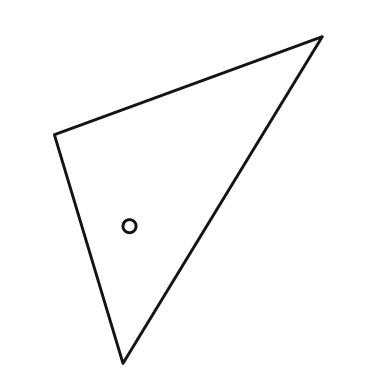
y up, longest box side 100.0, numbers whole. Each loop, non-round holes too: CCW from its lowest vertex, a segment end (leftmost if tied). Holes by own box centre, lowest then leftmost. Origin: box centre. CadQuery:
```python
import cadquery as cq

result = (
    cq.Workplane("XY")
    .moveTo(-20.0, -50.0)
    .lineTo(41.0, 50.0)
    .lineTo(-41.0, 20.0)
    .close()
    .moveTo(-18.0, -8.0)
    .circle(2.0)
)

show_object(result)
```